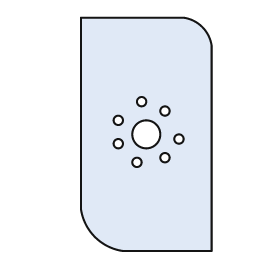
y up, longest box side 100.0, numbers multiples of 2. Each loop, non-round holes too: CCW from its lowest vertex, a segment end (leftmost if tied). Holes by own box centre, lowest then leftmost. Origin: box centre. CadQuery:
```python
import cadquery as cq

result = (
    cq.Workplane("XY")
    .moveTo(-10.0, -50.0)
    .lineTo(28.0, -50.0)
    .lineTo(28.0, 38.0)
    .threePointArc((24.0, 46.0), (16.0, 50.0))
    .lineTo(-28.0, 50.0)
    .lineTo(-28.0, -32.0)
    .threePointArc((-22.0, -44.0), (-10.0, -50.0))
    .close()
    .moveTo(-4.0, -12.0)
    .circle(2.0)
    .moveTo(8.0, -10.0)
    .circle(2.0)
    .moveTo(-12.0, -4.0)
    .circle(2.0)
    .moveTo(14.0, -2.0)
    .circle(2.0)
    .moveTo(0.0, 0.0)
    .circle(6.0)
    .moveTo(-12.0, 6.0)
    .circle(2.0)
    .moveTo(8.0, 10.0)
    .circle(2.0)
    .moveTo(-2.0, 14.0)
    .circle(2.0)
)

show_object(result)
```